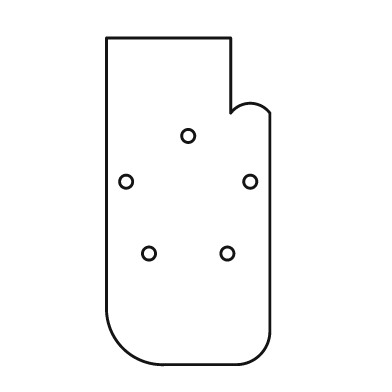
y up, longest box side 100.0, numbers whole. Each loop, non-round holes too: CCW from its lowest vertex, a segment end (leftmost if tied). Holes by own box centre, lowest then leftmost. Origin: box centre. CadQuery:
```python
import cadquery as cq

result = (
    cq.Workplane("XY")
    .moveTo(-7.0, -50.0)
    .lineTo(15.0, -50.0)
    .threePointArc((22.0, -47.0), (25.0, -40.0))
    .lineTo(25.0, 27.0)
    .threePointArc((19.0, 30.0), (13.0, 27.0))
    .lineTo(13.0, 50.0)
    .lineTo(-25.0, 50.0)
    .lineTo(-25.0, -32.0)
    .threePointArc((-20.0, -45.0), (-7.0, -50.0))
    .close()
    .moveTo(-12.0, -16.0)
    .circle(2.0)
    .moveTo(12.0, -16.0)
    .circle(2.0)
    .moveTo(-19.0, 6.0)
    .circle(2.0)
    .moveTo(19.0, 6.0)
    .circle(2.0)
    .moveTo(0.0, 20.0)
    .circle(2.0)
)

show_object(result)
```